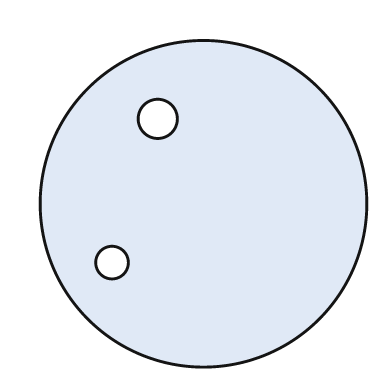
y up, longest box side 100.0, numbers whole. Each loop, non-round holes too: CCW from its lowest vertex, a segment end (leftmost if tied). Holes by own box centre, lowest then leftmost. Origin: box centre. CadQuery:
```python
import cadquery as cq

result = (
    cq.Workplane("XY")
    .moveTo(0.0, 0.0)
    .circle(50.0)
    .moveTo(-28.0, -18.0)
    .circle(5.0)
    .moveTo(-14.0, 26.0)
    .circle(6.0)
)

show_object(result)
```